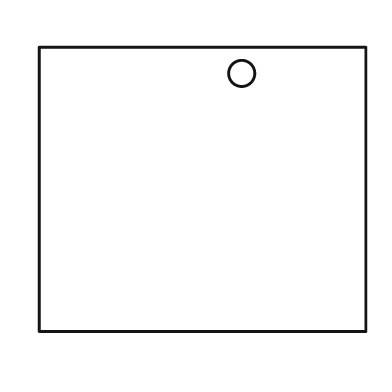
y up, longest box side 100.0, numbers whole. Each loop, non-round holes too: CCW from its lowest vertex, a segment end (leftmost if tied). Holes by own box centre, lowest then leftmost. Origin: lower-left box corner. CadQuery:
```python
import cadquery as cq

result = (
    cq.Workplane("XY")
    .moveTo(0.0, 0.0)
    .lineTo(100.0, 0.0)
    .lineTo(100.0, 87.0)
    .lineTo(0.0, 87.0)
    .close()
    .moveTo(62.0, 79.0)
    .circle(4.0)
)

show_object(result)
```